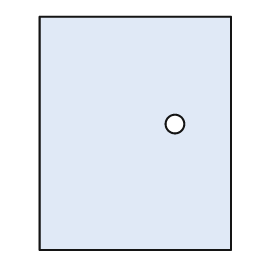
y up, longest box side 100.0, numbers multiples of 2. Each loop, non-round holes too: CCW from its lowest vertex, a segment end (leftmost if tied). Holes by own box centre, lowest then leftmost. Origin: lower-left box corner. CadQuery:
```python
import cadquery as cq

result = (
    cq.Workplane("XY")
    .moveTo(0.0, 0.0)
    .lineTo(82.0, 0.0)
    .lineTo(82.0, 100.0)
    .lineTo(0.0, 100.0)
    .close()
    .moveTo(58.0, 54.0)
    .circle(4.0)
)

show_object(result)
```